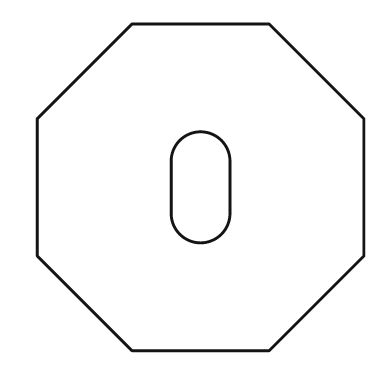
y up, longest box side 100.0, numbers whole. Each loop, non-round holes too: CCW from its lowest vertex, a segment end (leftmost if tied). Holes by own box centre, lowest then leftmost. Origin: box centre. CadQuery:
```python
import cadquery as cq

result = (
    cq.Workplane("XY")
    .moveTo(-21.0, -50.0)
    .lineTo(21.0, -50.0)
    .lineTo(50.0, -21.0)
    .lineTo(50.0, 21.0)
    .lineTo(21.0, 50.0)
    .lineTo(-21.0, 50.0)
    .lineTo(-50.0, 21.0)
    .lineTo(-50.0, -21.0)
    .close()
    .moveTo(-9.0, -8.0)
    .threePointArc((0.0, -17.0), (9.0, -8.0))
    .lineTo(9.0, 8.0)
    .threePointArc((0.0, 17.0), (-9.0, 8.0))
    .close()
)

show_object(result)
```